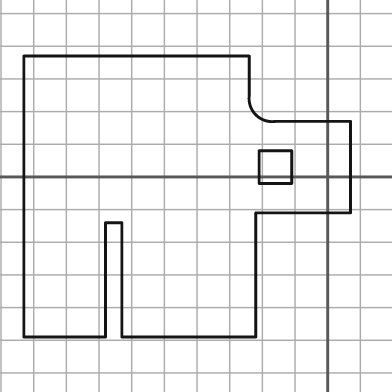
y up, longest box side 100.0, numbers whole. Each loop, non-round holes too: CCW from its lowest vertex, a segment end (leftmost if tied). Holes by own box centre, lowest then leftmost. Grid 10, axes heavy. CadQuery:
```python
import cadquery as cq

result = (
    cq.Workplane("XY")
    .moveTo(-93.0, -49.0)
    .lineTo(-68.0, -49.0)
    .lineTo(-68.0, -14.0)
    .lineTo(-63.0, -14.0)
    .lineTo(-63.0, -49.0)
    .lineTo(-22.0, -49.0)
    .lineTo(-22.0, -11.0)
    .lineTo(7.0, -11.0)
    .lineTo(7.0, 17.0)
    .lineTo(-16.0, 17.0)
    .threePointArc((-22.0, 19.0), (-24.0, 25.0))
    .lineTo(-24.0, 37.0)
    .lineTo(-93.0, 37.0)
    .close()
    .moveTo(-21.0, -2.0)
    .lineTo(-11.0, -2.0)
    .lineTo(-11.0, 8.0)
    .lineTo(-21.0, 8.0)
    .close()
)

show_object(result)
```